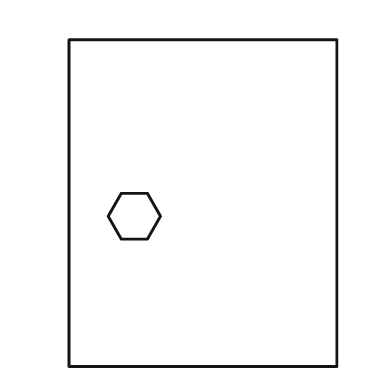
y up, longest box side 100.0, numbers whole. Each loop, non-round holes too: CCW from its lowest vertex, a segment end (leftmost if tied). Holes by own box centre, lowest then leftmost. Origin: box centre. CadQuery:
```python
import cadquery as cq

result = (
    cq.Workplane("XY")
    .moveTo(-41.0, -50.0)
    .lineTo(41.0, -50.0)
    .lineTo(41.0, 50.0)
    .lineTo(-41.0, 50.0)
    .close()
    .moveTo(-25.0, -11.0)
    .lineTo(-17.0, -11.0)
    .lineTo(-13.0, -4.0)
    .lineTo(-17.0, 3.0)
    .lineTo(-25.0, 3.0)
    .lineTo(-29.0, -4.0)
    .close()
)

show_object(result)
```